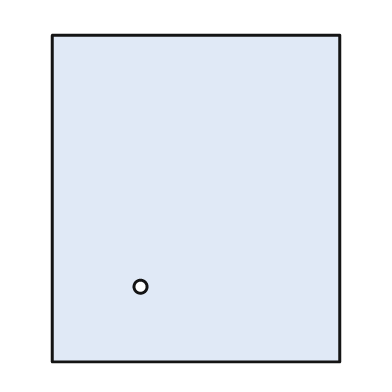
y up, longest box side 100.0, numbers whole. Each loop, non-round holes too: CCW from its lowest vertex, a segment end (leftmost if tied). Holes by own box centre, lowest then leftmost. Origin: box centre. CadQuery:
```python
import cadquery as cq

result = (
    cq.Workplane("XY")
    .moveTo(-44.0, -50.0)
    .lineTo(44.0, -50.0)
    .lineTo(44.0, 50.0)
    .lineTo(-44.0, 50.0)
    .close()
    .moveTo(-17.0, -27.0)
    .circle(2.0)
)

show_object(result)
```